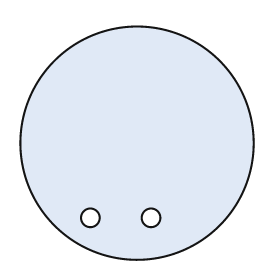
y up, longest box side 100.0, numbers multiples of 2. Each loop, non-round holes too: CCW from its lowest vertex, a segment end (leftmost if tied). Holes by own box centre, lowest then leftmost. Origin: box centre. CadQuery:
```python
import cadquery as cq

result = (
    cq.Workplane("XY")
    .moveTo(0.0, 0.0)
    .circle(50.0)
    .moveTo(-20.0, -32.0)
    .circle(4.0)
    .moveTo(6.0, -32.0)
    .circle(4.0)
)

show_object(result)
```